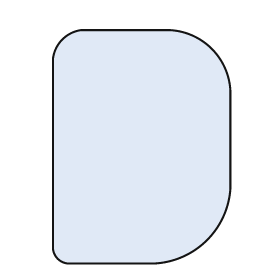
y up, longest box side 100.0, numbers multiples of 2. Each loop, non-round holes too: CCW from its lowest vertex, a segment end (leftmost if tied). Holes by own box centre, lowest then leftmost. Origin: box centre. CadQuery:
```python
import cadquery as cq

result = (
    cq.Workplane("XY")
    .moveTo(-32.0, -50.0)
    .lineTo(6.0, -50.0)
    .threePointArc((28.0, -40.0), (38.0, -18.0))
    .lineTo(38.0, 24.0)
    .threePointArc((30.0, 42.0), (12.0, 50.0))
    .lineTo(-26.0, 50.0)
    .threePointArc((-34.0, 46.0), (-38.0, 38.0))
    .lineTo(-38.0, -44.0)
    .threePointArc((-36.0, -48.0), (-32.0, -50.0))
    .close()
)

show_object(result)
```